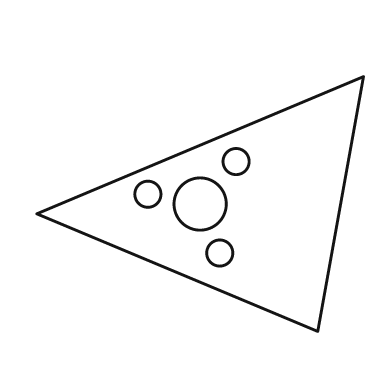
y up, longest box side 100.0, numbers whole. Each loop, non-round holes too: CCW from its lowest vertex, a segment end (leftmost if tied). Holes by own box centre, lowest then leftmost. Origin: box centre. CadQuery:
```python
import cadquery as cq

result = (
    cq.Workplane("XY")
    .moveTo(36.0, -39.0)
    .lineTo(50.0, 39.0)
    .lineTo(-50.0, -3.0)
    .close()
    .moveTo(6.0, -15.0)
    .circle(4.0)
    .moveTo(0.0, 0.0)
    .circle(8.0)
    .moveTo(-16.0, 3.0)
    .circle(4.0)
    .moveTo(11.0, 13.0)
    .circle(4.0)
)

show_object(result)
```